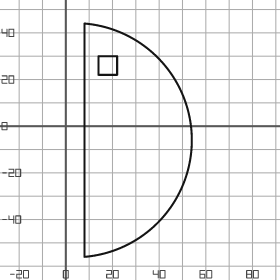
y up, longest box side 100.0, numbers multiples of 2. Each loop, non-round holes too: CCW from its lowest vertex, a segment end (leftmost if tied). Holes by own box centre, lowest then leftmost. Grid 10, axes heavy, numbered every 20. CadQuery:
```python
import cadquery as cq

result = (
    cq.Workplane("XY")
    .moveTo(8.0, -56.0)
    .threePointArc((54.0, -6.0), (8.0, 44.0))
    .close()
    .moveTo(14.0, 22.0)
    .lineTo(22.0, 22.0)
    .lineTo(22.0, 30.0)
    .lineTo(14.0, 30.0)
    .close()
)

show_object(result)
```